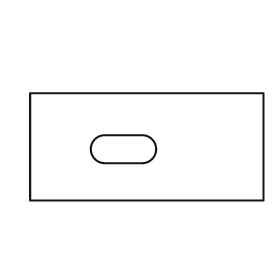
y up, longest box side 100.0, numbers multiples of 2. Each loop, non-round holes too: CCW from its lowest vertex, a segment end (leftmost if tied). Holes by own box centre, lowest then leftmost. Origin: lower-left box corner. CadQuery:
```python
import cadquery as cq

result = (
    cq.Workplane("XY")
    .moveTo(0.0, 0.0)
    .lineTo(100.0, 0.0)
    .lineTo(100.0, 46.0)
    .lineTo(0.0, 46.0)
    .close()
    .moveTo(32.0, 16.0)
    .lineTo(48.0, 16.0)
    .threePointArc((54.0, 22.0), (48.0, 28.0))
    .lineTo(32.0, 28.0)
    .threePointArc((26.0, 22.0), (32.0, 16.0))
    .close()
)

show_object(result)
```